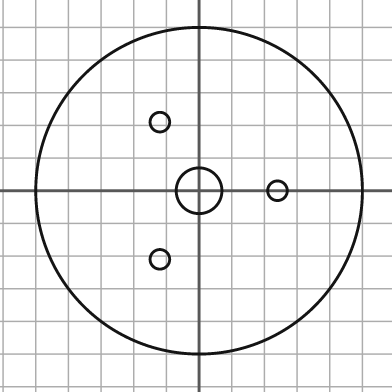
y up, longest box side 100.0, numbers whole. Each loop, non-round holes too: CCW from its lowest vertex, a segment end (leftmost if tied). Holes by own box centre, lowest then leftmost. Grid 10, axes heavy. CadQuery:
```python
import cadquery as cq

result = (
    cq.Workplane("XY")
    .moveTo(0.0, 0.0)
    .circle(50.0)
    .moveTo(-12.0, -21.0)
    .circle(3.0)
    .moveTo(0.0, 0.0)
    .circle(7.0)
    .moveTo(24.0, 0.0)
    .circle(3.0)
    .moveTo(-12.0, 21.0)
    .circle(3.0)
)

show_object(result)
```